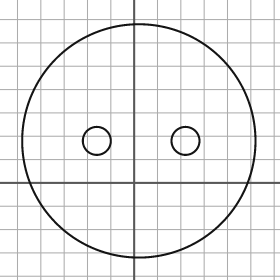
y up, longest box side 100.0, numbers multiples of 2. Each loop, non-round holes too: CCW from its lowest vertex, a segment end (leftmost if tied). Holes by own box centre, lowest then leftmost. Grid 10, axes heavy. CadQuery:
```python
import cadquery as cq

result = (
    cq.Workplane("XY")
    .moveTo(2.0, 18.0)
    .circle(50.0)
    .moveTo(-16.0, 18.0)
    .circle(6.0)
    .moveTo(22.0, 18.0)
    .circle(6.0)
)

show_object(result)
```